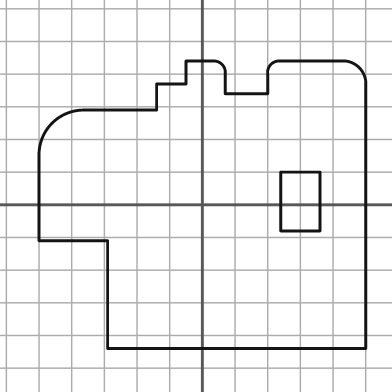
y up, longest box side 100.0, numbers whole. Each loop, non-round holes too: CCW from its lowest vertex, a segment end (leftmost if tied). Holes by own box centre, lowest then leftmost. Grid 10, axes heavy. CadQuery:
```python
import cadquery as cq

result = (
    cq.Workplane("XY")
    .moveTo(-29.0, -44.0)
    .lineTo(50.0, -44.0)
    .lineTo(50.0, 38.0)
    .threePointArc((48.0, 42.0), (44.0, 44.0))
    .lineTo(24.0, 44.0)
    .threePointArc((21.0, 43.0), (20.0, 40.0))
    .lineTo(20.0, 34.0)
    .lineTo(7.0, 34.0)
    .lineTo(7.0, 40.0)
    .threePointArc((6.0, 43.0), (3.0, 44.0))
    .lineTo(-5.0, 44.0)
    .lineTo(-5.0, 37.0)
    .lineTo(-14.0, 37.0)
    .lineTo(-14.0, 29.0)
    .lineTo(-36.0, 29.0)
    .threePointArc((-46.0, 25.0), (-50.0, 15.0))
    .lineTo(-50.0, -11.0)
    .lineTo(-29.0, -11.0)
    .close()
    .moveTo(24.0, -8.0)
    .lineTo(36.0, -8.0)
    .lineTo(36.0, 10.0)
    .lineTo(24.0, 10.0)
    .close()
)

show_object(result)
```